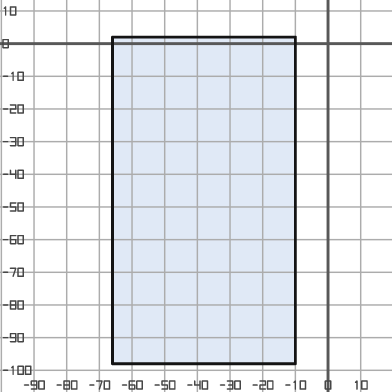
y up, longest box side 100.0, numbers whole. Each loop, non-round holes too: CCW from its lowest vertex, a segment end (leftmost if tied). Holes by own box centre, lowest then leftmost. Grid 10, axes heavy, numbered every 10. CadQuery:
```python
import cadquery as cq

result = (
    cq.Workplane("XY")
    .moveTo(-66.0, -98.0)
    .lineTo(-10.0, -98.0)
    .lineTo(-10.0, 2.0)
    .lineTo(-66.0, 2.0)
    .close()
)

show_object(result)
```